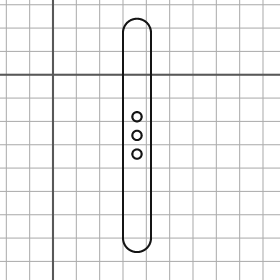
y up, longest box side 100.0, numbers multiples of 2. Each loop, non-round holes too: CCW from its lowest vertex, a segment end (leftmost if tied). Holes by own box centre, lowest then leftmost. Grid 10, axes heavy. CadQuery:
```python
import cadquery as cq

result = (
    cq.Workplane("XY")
    .moveTo(30.0, -70.0)
    .threePointArc((36.0, -76.0), (42.0, -70.0))
    .lineTo(42.0, 18.0)
    .threePointArc((36.0, 24.0), (30.0, 18.0))
    .close()
    .moveTo(36.0, -34.0)
    .circle(2.0)
    .moveTo(36.0, -26.0)
    .circle(2.0)
    .moveTo(36.0, -18.0)
    .circle(2.0)
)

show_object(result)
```